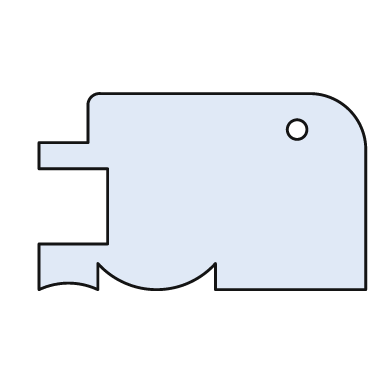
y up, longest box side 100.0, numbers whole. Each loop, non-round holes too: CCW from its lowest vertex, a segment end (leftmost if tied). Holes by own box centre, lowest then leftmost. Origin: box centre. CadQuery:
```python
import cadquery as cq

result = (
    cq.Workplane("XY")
    .moveTo(-50.0, -30.0)
    .threePointArc((-41.0, -28.0), (-32.0, -30.0))
    .lineTo(-32.0, -22.0)
    .threePointArc((-14.0, -30.0), (4.0, -22.0))
    .lineTo(4.0, -30.0)
    .lineTo(50.0, -30.0)
    .lineTo(50.0, 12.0)
    .threePointArc((45.0, 25.0), (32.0, 30.0))
    .lineTo(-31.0, 30.0)
    .threePointArc((-34.0, 29.0), (-35.0, 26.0))
    .lineTo(-35.0, 15.0)
    .lineTo(-50.0, 15.0)
    .lineTo(-50.0, 7.0)
    .lineTo(-29.0, 7.0)
    .lineTo(-29.0, -16.0)
    .lineTo(-50.0, -16.0)
    .close()
    .moveTo(29.0, 19.0)
    .circle(3.0)
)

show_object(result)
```